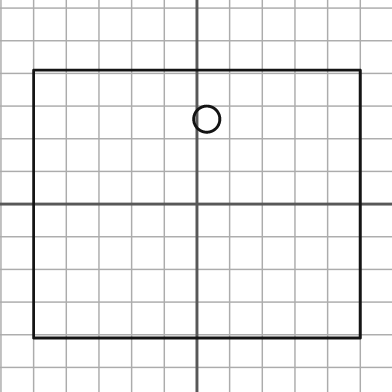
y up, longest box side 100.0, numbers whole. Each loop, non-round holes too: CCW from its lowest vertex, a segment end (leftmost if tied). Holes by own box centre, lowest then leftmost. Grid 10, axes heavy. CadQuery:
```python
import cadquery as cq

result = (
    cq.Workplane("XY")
    .moveTo(-50.0, -41.0)
    .lineTo(50.0, -41.0)
    .lineTo(50.0, 41.0)
    .lineTo(-50.0, 41.0)
    .close()
    .moveTo(3.0, 26.0)
    .circle(4.0)
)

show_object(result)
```